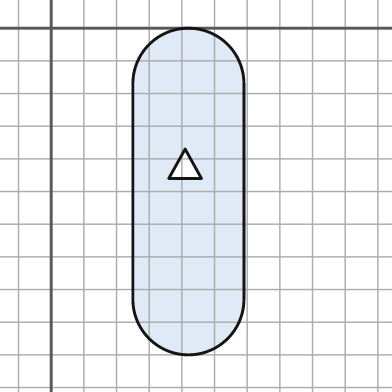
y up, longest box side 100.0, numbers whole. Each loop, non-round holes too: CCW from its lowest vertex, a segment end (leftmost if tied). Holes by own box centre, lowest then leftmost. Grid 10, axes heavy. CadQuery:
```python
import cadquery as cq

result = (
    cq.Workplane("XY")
    .moveTo(25.0, -83.0)
    .threePointArc((42.0, -100.0), (59.0, -83.0))
    .lineTo(59.0, -17.0)
    .threePointArc((42.0, 0.0), (25.0, -17.0))
    .close()
    .moveTo(36.0, -46.0)
    .lineTo(46.0, -46.0)
    .lineTo(41.0, -37.0)
    .close()
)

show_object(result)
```